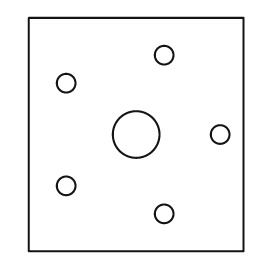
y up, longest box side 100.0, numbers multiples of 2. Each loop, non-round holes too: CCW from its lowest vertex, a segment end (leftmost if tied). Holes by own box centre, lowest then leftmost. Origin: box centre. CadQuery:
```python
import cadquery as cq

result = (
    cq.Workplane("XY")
    .moveTo(-46.0, -50.0)
    .lineTo(46.0, -50.0)
    .lineTo(46.0, 50.0)
    .lineTo(-46.0, 50.0)
    .close()
    .moveTo(12.0, -34.0)
    .circle(4.0)
    .moveTo(-30.0, -22.0)
    .circle(4.0)
    .moveTo(0.0, 0.0)
    .circle(10.0)
    .moveTo(36.0, 0.0)
    .circle(4.0)
    .moveTo(-30.0, 22.0)
    .circle(4.0)
    .moveTo(12.0, 34.0)
    .circle(4.0)
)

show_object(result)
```